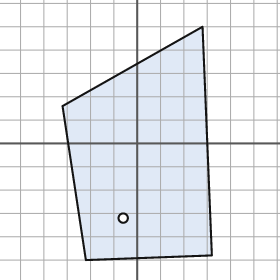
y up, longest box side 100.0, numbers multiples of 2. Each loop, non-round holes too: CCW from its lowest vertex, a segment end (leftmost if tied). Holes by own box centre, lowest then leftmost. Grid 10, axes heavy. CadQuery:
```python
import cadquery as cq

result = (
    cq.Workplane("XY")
    .moveTo(-22.0, -50.0)
    .lineTo(32.0, -48.0)
    .lineTo(28.0, 50.0)
    .lineTo(-32.0, 16.0)
    .close()
    .moveTo(-6.0, -32.0)
    .circle(2.0)
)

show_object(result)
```